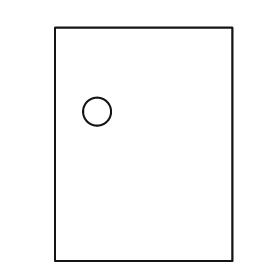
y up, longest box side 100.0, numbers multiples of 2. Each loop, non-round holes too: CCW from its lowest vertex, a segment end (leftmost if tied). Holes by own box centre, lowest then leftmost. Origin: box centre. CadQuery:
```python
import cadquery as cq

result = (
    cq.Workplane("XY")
    .moveTo(-38.0, -50.0)
    .lineTo(38.0, -50.0)
    .lineTo(38.0, 50.0)
    .lineTo(-38.0, 50.0)
    .close()
    .moveTo(-20.0, 14.0)
    .circle(6.0)
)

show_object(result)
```